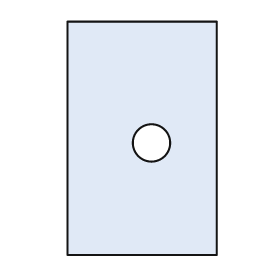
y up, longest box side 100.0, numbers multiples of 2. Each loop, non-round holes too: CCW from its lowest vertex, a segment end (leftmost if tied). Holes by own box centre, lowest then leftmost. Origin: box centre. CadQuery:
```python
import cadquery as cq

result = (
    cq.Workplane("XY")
    .moveTo(-32.0, -50.0)
    .lineTo(32.0, -50.0)
    .lineTo(32.0, 50.0)
    .lineTo(-32.0, 50.0)
    .close()
    .moveTo(4.0, -2.0)
    .circle(8.0)
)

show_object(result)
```